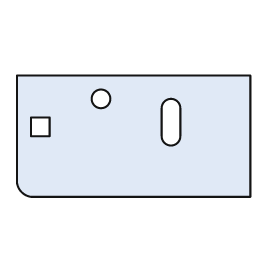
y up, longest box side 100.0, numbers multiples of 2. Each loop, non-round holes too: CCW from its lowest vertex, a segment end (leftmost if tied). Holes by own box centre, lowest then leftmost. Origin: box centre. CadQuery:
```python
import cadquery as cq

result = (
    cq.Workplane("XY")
    .moveTo(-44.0, -26.0)
    .lineTo(50.0, -26.0)
    .lineTo(50.0, 26.0)
    .lineTo(-50.0, 26.0)
    .lineTo(-50.0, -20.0)
    .threePointArc((-48.0, -24.0), (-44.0, -26.0))
    .close()
    .moveTo(-44.0, 0.0)
    .lineTo(-36.0, 0.0)
    .lineTo(-36.0, 8.0)
    .lineTo(-44.0, 8.0)
    .close()
    .moveTo(12.0, 0.0)
    .threePointArc((16.0, -4.0), (20.0, 0.0))
    .lineTo(20.0, 12.0)
    .threePointArc((16.0, 16.0), (12.0, 12.0))
    .close()
    .moveTo(-14.0, 16.0)
    .circle(4.0)
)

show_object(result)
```